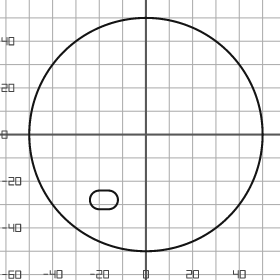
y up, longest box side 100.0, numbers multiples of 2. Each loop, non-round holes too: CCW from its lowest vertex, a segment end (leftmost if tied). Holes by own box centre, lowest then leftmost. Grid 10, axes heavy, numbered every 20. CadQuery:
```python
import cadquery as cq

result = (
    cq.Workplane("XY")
    .moveTo(0.0, 0.0)
    .circle(50.0)
    .moveTo(-20.0, -32.0)
    .lineTo(-16.0, -32.0)
    .threePointArc((-12.0, -28.0), (-16.0, -24.0))
    .lineTo(-20.0, -24.0)
    .threePointArc((-24.0, -28.0), (-20.0, -32.0))
    .close()
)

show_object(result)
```